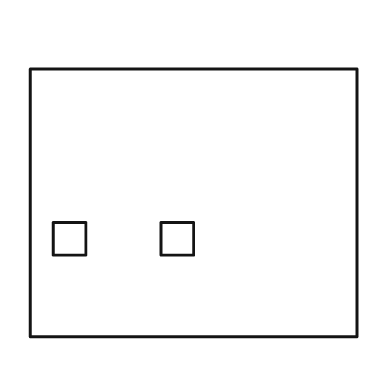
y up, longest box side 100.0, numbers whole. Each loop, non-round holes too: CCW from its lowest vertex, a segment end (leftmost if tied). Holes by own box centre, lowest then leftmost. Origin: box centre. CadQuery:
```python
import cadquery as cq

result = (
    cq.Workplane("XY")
    .moveTo(-50.0, -41.0)
    .lineTo(50.0, -41.0)
    .lineTo(50.0, 41.0)
    .lineTo(-50.0, 41.0)
    .close()
    .moveTo(-43.0, -16.0)
    .lineTo(-33.0, -16.0)
    .lineTo(-33.0, -6.0)
    .lineTo(-43.0, -6.0)
    .close()
    .moveTo(-10.0, -16.0)
    .lineTo(0.0, -16.0)
    .lineTo(0.0, -6.0)
    .lineTo(-10.0, -6.0)
    .close()
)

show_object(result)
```